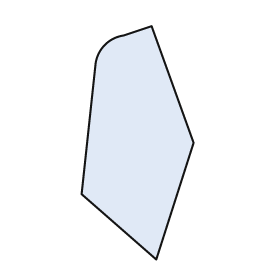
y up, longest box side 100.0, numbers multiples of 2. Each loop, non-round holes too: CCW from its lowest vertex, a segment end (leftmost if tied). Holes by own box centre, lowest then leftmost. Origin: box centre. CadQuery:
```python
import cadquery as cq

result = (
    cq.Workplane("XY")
    .moveTo(8.0, -50.0)
    .lineTo(24.0, 0.0)
    .lineTo(6.0, 50.0)
    .lineTo(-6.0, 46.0)
    .threePointArc((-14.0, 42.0), (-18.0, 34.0))
    .lineTo(-24.0, -22.0)
    .close()
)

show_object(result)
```